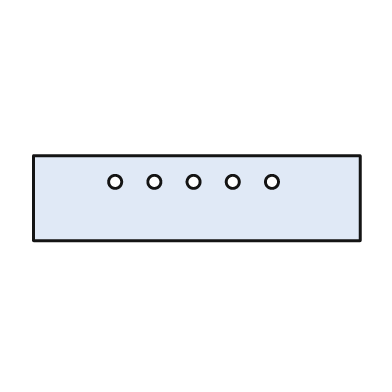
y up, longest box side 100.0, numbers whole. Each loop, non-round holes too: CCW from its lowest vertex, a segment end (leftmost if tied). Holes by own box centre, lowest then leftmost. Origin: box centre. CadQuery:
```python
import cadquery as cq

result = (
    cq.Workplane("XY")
    .moveTo(-50.0, -13.0)
    .lineTo(50.0, -13.0)
    .lineTo(50.0, 13.0)
    .lineTo(-50.0, 13.0)
    .close()
    .moveTo(-25.0, 5.0)
    .circle(2.0)
    .moveTo(-13.0, 5.0)
    .circle(2.0)
    .moveTo(-1.0, 5.0)
    .circle(2.0)
    .moveTo(11.0, 5.0)
    .circle(2.0)
    .moveTo(23.0, 5.0)
    .circle(2.0)
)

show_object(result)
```